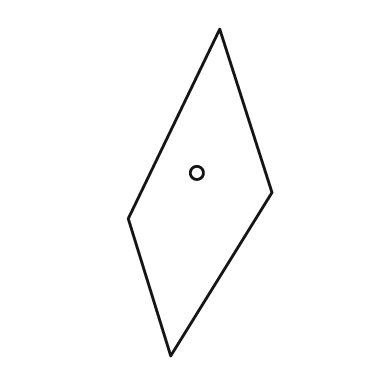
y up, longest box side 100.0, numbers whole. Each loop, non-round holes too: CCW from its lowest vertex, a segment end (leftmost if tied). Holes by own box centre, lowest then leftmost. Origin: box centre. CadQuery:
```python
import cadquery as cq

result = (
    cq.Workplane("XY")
    .moveTo(-9.0, -50.0)
    .lineTo(22.0, 0.0)
    .lineTo(6.0, 50.0)
    .lineTo(-22.0, -8.0)
    .close()
    .moveTo(-1.0, 6.0)
    .circle(2.0)
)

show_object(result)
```